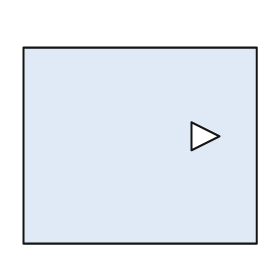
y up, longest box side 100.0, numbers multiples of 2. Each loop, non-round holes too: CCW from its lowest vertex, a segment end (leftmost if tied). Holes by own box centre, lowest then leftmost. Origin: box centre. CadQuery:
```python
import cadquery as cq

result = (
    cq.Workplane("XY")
    .moveTo(-50.0, -42.0)
    .lineTo(50.0, -42.0)
    .lineTo(50.0, 42.0)
    .lineTo(-50.0, 42.0)
    .close()
    .moveTo(22.0, -2.0)
    .lineTo(34.0, 4.0)
    .lineTo(22.0, 10.0)
    .close()
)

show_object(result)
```